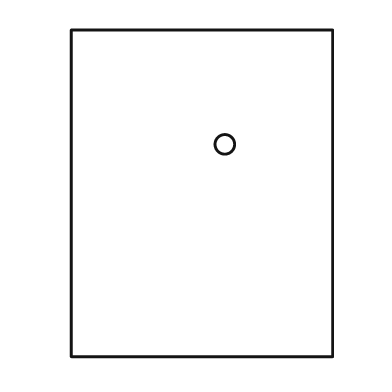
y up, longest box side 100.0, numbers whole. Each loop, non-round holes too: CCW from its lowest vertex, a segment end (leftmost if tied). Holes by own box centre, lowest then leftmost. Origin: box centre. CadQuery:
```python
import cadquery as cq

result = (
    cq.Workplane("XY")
    .moveTo(-40.0, -50.0)
    .lineTo(40.0, -50.0)
    .lineTo(40.0, 50.0)
    .lineTo(-40.0, 50.0)
    .close()
    .moveTo(7.0, 15.0)
    .circle(3.0)
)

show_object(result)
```